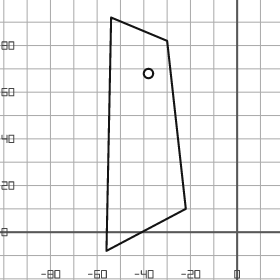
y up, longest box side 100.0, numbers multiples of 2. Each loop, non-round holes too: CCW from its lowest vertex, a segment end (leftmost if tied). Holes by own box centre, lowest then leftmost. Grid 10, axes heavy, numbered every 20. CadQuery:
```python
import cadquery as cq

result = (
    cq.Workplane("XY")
    .moveTo(-56.0, -8.0)
    .lineTo(-22.0, 10.0)
    .lineTo(-30.0, 82.0)
    .lineTo(-54.0, 92.0)
    .close()
    .moveTo(-38.0, 68.0)
    .circle(2.0)
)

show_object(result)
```